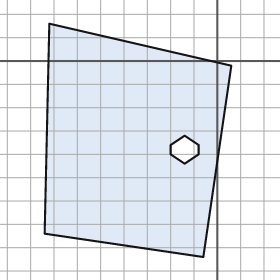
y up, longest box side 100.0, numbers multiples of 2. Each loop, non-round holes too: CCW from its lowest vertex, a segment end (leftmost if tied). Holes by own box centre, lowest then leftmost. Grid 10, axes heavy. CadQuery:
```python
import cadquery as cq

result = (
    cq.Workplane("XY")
    .moveTo(-6.0, -84.0)
    .lineTo(6.0, -2.0)
    .lineTo(-72.0, 16.0)
    .lineTo(-74.0, -74.0)
    .close()
    .moveTo(-14.0, -44.0)
    .lineTo(-8.0, -40.0)
    .lineTo(-8.0, -36.0)
    .lineTo(-14.0, -32.0)
    .lineTo(-20.0, -36.0)
    .lineTo(-20.0, -40.0)
    .close()
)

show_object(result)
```